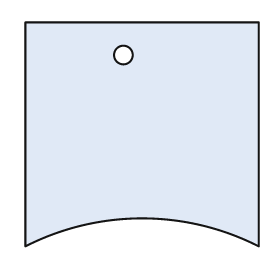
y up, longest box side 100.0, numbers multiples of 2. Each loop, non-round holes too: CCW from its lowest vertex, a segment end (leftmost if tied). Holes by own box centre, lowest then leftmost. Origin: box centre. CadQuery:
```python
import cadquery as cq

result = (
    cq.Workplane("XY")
    .moveTo(-50.0, -48.0)
    .threePointArc((0.0, -36.0), (50.0, -48.0))
    .lineTo(50.0, 48.0)
    .lineTo(-50.0, 48.0)
    .close()
    .moveTo(-8.0, 34.0)
    .circle(4.0)
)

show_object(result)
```